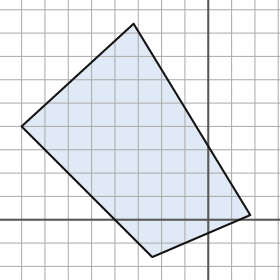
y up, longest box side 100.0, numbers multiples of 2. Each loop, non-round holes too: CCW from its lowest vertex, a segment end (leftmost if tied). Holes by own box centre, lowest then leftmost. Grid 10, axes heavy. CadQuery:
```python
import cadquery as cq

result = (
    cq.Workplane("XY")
    .moveTo(-24.0, -16.0)
    .lineTo(18.0, 2.0)
    .lineTo(-32.0, 84.0)
    .lineTo(-80.0, 40.0)
    .close()
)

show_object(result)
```